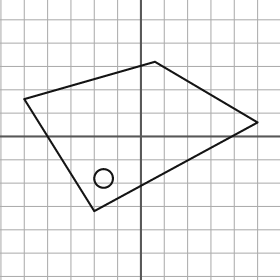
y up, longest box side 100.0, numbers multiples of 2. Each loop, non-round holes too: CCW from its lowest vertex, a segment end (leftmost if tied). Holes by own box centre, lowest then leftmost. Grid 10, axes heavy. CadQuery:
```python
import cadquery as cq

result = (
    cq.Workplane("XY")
    .moveTo(-20.0, -32.0)
    .lineTo(50.0, 6.0)
    .lineTo(6.0, 32.0)
    .lineTo(-50.0, 16.0)
    .close()
    .moveTo(-16.0, -18.0)
    .circle(4.0)
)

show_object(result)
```